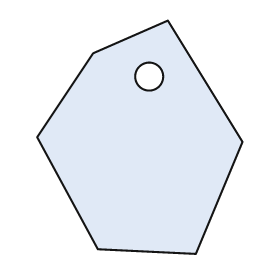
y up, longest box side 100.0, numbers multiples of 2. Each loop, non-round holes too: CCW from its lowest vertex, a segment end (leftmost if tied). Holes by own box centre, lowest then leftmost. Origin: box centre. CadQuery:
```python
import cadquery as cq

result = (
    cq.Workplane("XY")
    .moveTo(24.0, -50.0)
    .lineTo(44.0, -2.0)
    .lineTo(12.0, 50.0)
    .lineTo(-20.0, 36.0)
    .lineTo(-44.0, 0.0)
    .lineTo(-18.0, -48.0)
    .close()
    .moveTo(4.0, 26.0)
    .circle(6.0)
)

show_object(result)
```